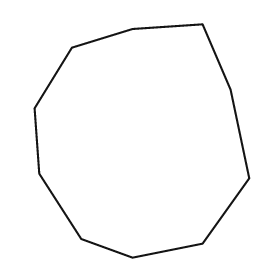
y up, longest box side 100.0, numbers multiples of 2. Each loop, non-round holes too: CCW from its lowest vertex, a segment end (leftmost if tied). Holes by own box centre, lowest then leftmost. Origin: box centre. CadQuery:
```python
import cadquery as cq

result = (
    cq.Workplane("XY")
    .moveTo(-4.0, -50.0)
    .lineTo(26.0, -44.0)
    .lineTo(46.0, -16.0)
    .lineTo(38.0, 22.0)
    .lineTo(26.0, 50.0)
    .lineTo(-4.0, 48.0)
    .lineTo(-30.0, 40.0)
    .lineTo(-46.0, 14.0)
    .lineTo(-44.0, -14.0)
    .lineTo(-26.0, -42.0)
    .close()
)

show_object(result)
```